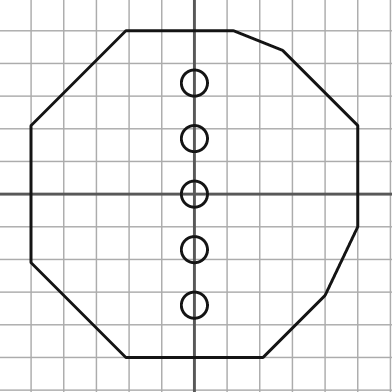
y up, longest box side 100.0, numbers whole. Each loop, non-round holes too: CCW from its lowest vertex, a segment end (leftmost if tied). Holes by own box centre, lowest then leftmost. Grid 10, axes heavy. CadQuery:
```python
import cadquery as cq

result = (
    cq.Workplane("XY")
    .moveTo(-21.0, -50.0)
    .lineTo(21.0, -50.0)
    .lineTo(40.0, -31.0)
    .lineTo(50.0, -10.0)
    .lineTo(50.0, 21.0)
    .lineTo(27.0, 44.0)
    .lineTo(12.0, 50.0)
    .lineTo(-21.0, 50.0)
    .lineTo(-50.0, 21.0)
    .lineTo(-50.0, -21.0)
    .close()
    .moveTo(0.0, -34.0)
    .circle(4.0)
    .moveTo(0.0, -17.0)
    .circle(4.0)
    .moveTo(0.0, 0.0)
    .circle(4.0)
    .moveTo(0.0, 17.0)
    .circle(4.0)
    .moveTo(0.0, 34.0)
    .circle(4.0)
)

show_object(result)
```